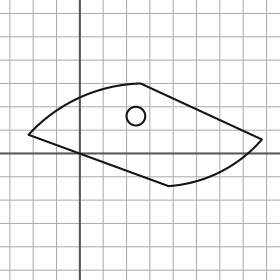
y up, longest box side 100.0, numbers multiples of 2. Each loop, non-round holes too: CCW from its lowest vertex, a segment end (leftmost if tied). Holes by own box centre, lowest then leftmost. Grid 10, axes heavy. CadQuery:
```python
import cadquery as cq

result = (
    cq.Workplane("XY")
    .moveTo(38.0, -14.0)
    .threePointArc((60.0, -8.0), (78.0, 6.0))
    .lineTo(26.0, 30.0)
    .threePointArc((0.0, 24.0), (-22.0, 8.0))
    .close()
    .moveTo(24.0, 16.0)
    .circle(4.0)
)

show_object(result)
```